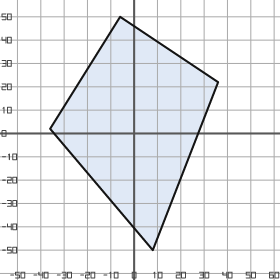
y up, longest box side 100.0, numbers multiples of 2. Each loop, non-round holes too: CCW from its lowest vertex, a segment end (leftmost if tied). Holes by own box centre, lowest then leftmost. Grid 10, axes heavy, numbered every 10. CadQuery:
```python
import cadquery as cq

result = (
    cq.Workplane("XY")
    .moveTo(8.0, -50.0)
    .lineTo(36.0, 22.0)
    .lineTo(-6.0, 50.0)
    .lineTo(-36.0, 2.0)
    .close()
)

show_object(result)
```